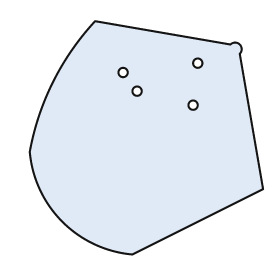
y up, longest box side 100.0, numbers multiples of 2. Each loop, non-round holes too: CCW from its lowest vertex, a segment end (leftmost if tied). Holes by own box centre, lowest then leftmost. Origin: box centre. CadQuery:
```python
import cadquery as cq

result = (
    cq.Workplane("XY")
    .moveTo(-6.0, -50.0)
    .lineTo(50.0, -22.0)
    .lineTo(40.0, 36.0)
    .threePointArc((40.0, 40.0), (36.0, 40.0))
    .lineTo(-22.0, 50.0)
    .threePointArc((-40.0, 24.0), (-50.0, -6.0))
    .threePointArc((-36.0, -36.0), (-6.0, -50.0))
    .close()
    .moveTo(20.0, 14.0)
    .circle(2.0)
    .moveTo(-4.0, 20.0)
    .circle(2.0)
    .moveTo(-10.0, 28.0)
    .circle(2.0)
    .moveTo(22.0, 32.0)
    .circle(2.0)
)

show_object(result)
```